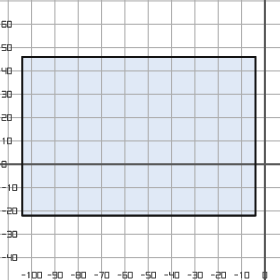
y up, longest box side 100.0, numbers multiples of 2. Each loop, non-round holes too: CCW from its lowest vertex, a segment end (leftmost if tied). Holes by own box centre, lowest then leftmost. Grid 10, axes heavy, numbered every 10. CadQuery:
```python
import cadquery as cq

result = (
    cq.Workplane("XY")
    .moveTo(-104.0, -22.0)
    .lineTo(-4.0, -22.0)
    .lineTo(-4.0, 46.0)
    .lineTo(-104.0, 46.0)
    .close()
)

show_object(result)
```